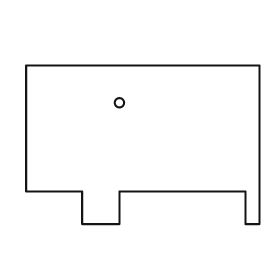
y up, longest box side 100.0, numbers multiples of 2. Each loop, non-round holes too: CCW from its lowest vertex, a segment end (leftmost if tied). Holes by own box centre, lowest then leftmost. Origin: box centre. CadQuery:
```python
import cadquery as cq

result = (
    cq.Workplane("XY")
    .moveTo(-26.0, -34.0)
    .lineTo(-10.0, -34.0)
    .lineTo(-10.0, -20.0)
    .lineTo(44.0, -20.0)
    .lineTo(44.0, -34.0)
    .lineTo(50.0, -34.0)
    .lineTo(50.0, 34.0)
    .lineTo(-50.0, 34.0)
    .lineTo(-50.0, -20.0)
    .lineTo(-26.0, -20.0)
    .close()
    .moveTo(-10.0, 18.0)
    .circle(2.0)
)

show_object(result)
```